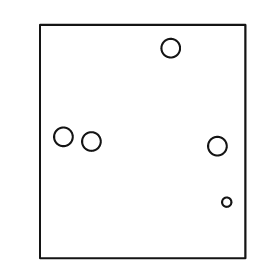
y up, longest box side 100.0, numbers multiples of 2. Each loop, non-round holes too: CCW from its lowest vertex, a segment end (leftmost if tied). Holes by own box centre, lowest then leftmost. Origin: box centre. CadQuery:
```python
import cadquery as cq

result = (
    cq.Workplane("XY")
    .moveTo(-44.0, -50.0)
    .lineTo(44.0, -50.0)
    .lineTo(44.0, 50.0)
    .lineTo(-44.0, 50.0)
    .close()
    .moveTo(36.0, -26.0)
    .circle(2.0)
    .moveTo(32.0, -2.0)
    .circle(4.0)
    .moveTo(-22.0, 0.0)
    .circle(4.0)
    .moveTo(-34.0, 2.0)
    .circle(4.0)
    .moveTo(12.0, 40.0)
    .circle(4.0)
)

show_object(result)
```